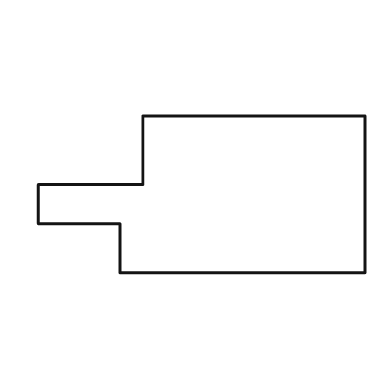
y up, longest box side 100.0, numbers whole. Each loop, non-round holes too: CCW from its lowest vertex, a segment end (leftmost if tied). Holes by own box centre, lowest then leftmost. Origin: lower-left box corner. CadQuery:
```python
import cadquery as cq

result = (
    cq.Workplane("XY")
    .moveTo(25.0, 0.0)
    .lineTo(100.0, 0.0)
    .lineTo(100.0, 48.0)
    .lineTo(32.0, 48.0)
    .lineTo(32.0, 27.0)
    .lineTo(0.0, 27.0)
    .lineTo(0.0, 15.0)
    .lineTo(25.0, 15.0)
    .close()
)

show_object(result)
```